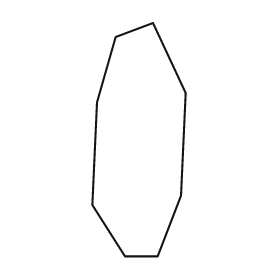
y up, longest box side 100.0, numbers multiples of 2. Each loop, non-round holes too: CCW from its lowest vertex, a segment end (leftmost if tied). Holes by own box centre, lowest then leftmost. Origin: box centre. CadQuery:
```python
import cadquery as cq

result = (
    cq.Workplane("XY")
    .moveTo(-6.0, -50.0)
    .lineTo(8.0, -50.0)
    .lineTo(18.0, -24.0)
    .lineTo(20.0, 20.0)
    .lineTo(6.0, 50.0)
    .lineTo(-10.0, 44.0)
    .lineTo(-18.0, 16.0)
    .lineTo(-20.0, -28.0)
    .close()
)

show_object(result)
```